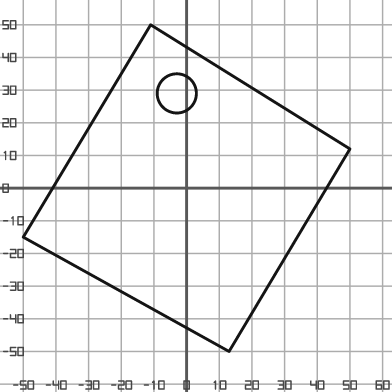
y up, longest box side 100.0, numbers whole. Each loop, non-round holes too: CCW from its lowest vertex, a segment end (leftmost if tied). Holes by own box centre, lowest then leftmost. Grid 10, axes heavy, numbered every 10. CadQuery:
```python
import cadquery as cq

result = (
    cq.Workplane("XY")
    .moveTo(13.0, -50.0)
    .lineTo(50.0, 12.0)
    .lineTo(-11.0, 50.0)
    .lineTo(-50.0, -15.0)
    .close()
    .moveTo(-3.0, 29.0)
    .circle(6.0)
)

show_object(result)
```